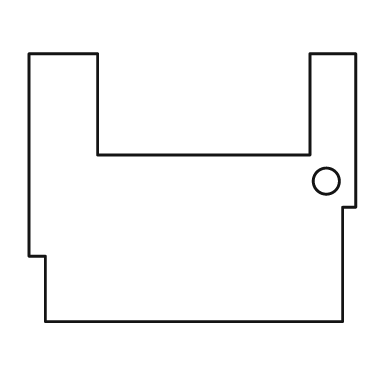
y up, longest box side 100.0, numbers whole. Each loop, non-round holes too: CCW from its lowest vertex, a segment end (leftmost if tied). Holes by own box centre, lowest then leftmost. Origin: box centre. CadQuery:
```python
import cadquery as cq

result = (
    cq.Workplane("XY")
    .moveTo(-45.0, -41.0)
    .lineTo(46.0, -41.0)
    .lineTo(46.0, -6.0)
    .lineTo(50.0, -6.0)
    .lineTo(50.0, 41.0)
    .lineTo(36.0, 41.0)
    .lineTo(36.0, 10.0)
    .lineTo(-29.0, 10.0)
    .lineTo(-29.0, 41.0)
    .lineTo(-50.0, 41.0)
    .lineTo(-50.0, -21.0)
    .lineTo(-45.0, -21.0)
    .close()
    .moveTo(41.0, 2.0)
    .circle(4.0)
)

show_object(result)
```